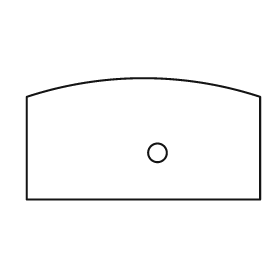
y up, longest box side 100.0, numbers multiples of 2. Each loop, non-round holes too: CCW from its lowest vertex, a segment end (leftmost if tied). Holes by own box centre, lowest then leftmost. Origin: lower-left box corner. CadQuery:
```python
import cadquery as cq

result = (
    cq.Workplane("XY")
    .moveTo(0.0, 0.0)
    .lineTo(100.0, 0.0)
    .lineTo(100.0, 44.0)
    .threePointArc((50.0, 52.0), (0.0, 44.0))
    .close()
    .moveTo(56.0, 20.0)
    .circle(4.0)
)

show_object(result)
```